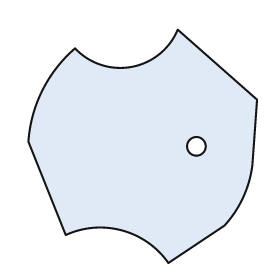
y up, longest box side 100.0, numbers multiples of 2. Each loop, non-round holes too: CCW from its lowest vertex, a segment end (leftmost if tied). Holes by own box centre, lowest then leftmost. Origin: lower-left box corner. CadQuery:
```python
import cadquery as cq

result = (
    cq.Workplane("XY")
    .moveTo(60.0, 0.0)
    .lineTo(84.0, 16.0)
    .threePointArc((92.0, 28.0), (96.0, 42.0))
    .lineTo(98.0, 70.0)
    .lineTo(64.0, 100.0)
    .threePointArc((44.0, 84.0), (20.0, 92.0))
    .threePointArc((6.0, 74.0), (0.0, 52.0))
    .lineTo(16.0, 12.0)
    .threePointArc((40.0, 14.0), (60.0, 0.0))
    .close()
    .moveTo(72.0, 50.0)
    .circle(4.0)
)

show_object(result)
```